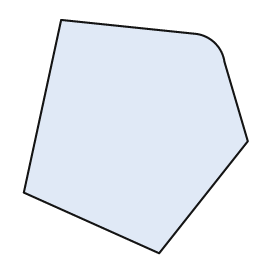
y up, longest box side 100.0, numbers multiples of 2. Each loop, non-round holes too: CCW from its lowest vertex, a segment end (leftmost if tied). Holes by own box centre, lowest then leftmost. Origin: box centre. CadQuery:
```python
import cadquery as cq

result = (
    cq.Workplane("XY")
    .moveTo(10.0, -50.0)
    .lineTo(48.0, -2.0)
    .lineTo(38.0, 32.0)
    .threePointArc((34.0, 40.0), (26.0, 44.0))
    .lineTo(-32.0, 50.0)
    .lineTo(-48.0, -24.0)
    .close()
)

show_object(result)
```